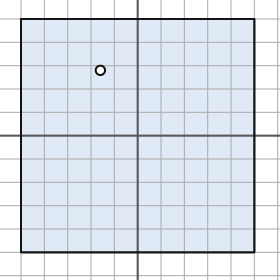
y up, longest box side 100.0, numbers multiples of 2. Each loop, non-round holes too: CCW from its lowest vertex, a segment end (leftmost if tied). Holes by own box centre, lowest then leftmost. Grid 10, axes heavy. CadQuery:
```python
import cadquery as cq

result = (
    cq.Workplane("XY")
    .moveTo(-50.0, -50.0)
    .lineTo(50.0, -50.0)
    .lineTo(50.0, 50.0)
    .lineTo(-50.0, 50.0)
    .close()
    .moveTo(-16.0, 28.0)
    .circle(2.0)
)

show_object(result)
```